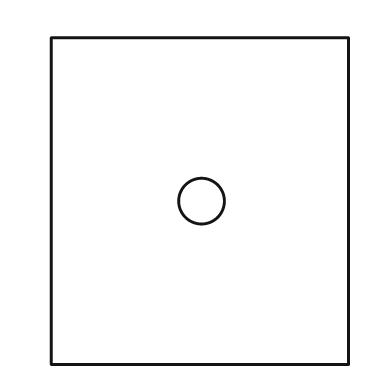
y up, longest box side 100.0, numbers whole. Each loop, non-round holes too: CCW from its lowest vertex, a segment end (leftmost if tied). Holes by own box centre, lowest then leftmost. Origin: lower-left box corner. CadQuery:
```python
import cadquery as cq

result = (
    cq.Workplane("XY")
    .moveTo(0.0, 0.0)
    .lineTo(91.0, 0.0)
    .lineTo(91.0, 100.0)
    .lineTo(0.0, 100.0)
    .close()
    .moveTo(46.0, 50.0)
    .circle(7.0)
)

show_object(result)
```